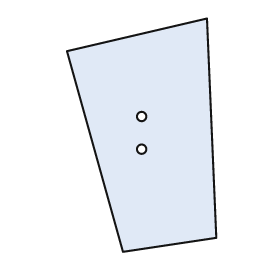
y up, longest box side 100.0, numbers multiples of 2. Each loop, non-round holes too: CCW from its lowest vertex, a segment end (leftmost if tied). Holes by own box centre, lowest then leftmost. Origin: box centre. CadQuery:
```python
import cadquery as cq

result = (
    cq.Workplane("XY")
    .moveTo(-8.0, -50.0)
    .lineTo(32.0, -44.0)
    .lineTo(28.0, 50.0)
    .lineTo(-32.0, 36.0)
    .close()
    .moveTo(0.0, -6.0)
    .circle(2.0)
    .moveTo(0.0, 8.0)
    .circle(2.0)
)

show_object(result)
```